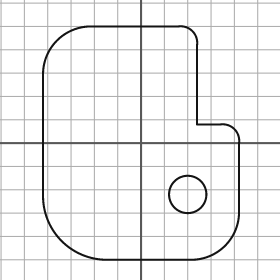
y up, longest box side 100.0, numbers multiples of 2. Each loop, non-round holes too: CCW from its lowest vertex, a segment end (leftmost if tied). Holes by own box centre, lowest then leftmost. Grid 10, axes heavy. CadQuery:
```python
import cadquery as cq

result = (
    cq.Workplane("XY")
    .moveTo(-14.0, -50.0)
    .lineTo(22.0, -50.0)
    .threePointArc((36.0, -44.0), (42.0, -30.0))
    .lineTo(42.0, 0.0)
    .threePointArc((40.0, 6.0), (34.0, 8.0))
    .lineTo(24.0, 8.0)
    .lineTo(24.0, 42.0)
    .threePointArc((22.0, 48.0), (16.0, 50.0))
    .lineTo(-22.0, 50.0)
    .threePointArc((-36.0, 44.0), (-42.0, 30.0))
    .lineTo(-42.0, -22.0)
    .threePointArc((-34.0, -42.0), (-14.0, -50.0))
    .close()
    .moveTo(20.0, -22.0)
    .circle(8.0)
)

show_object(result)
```